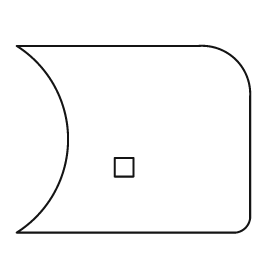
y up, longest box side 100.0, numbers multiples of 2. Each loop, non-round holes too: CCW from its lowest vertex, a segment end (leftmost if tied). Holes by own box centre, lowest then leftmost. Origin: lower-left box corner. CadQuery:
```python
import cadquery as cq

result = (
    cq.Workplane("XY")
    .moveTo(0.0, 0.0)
    .lineTo(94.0, 0.0)
    .threePointArc((98.0, 2.0), (100.0, 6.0))
    .lineTo(100.0, 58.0)
    .threePointArc((94.0, 74.0), (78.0, 80.0))
    .lineTo(0.0, 80.0)
    .threePointArc((22.0, 40.0), (0.0, 0.0))
    .close()
    .moveTo(42.0, 24.0)
    .lineTo(50.0, 24.0)
    .lineTo(50.0, 32.0)
    .lineTo(42.0, 32.0)
    .close()
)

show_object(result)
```